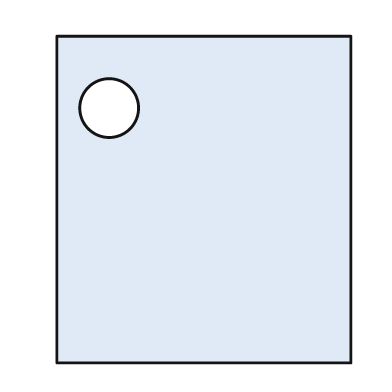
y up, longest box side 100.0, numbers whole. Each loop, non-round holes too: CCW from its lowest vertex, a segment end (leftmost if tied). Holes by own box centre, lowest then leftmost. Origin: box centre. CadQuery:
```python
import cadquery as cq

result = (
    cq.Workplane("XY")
    .moveTo(-45.0, -50.0)
    .lineTo(45.0, -50.0)
    .lineTo(45.0, 50.0)
    .lineTo(-45.0, 50.0)
    .close()
    .moveTo(-29.0, 28.0)
    .circle(9.0)
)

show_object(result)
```